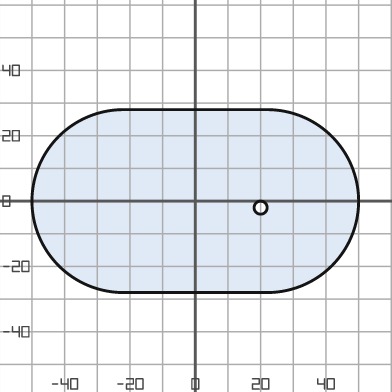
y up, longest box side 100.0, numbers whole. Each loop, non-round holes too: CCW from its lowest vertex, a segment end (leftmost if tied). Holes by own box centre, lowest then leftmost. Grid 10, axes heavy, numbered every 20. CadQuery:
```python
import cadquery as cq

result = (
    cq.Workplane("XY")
    .moveTo(-22.0, -28.0)
    .lineTo(22.0, -28.0)
    .threePointArc((50.0, 0.0), (22.0, 28.0))
    .lineTo(-22.0, 28.0)
    .threePointArc((-50.0, 0.0), (-22.0, -28.0))
    .close()
    .moveTo(20.0, -2.0)
    .circle(2.0)
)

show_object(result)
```